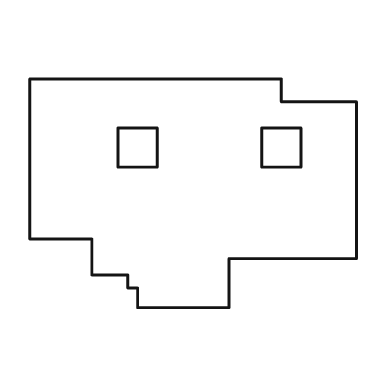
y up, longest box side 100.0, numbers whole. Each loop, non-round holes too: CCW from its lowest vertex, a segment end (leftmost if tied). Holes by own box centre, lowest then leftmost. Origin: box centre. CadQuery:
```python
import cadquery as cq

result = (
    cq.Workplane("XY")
    .moveTo(-17.0, -35.0)
    .lineTo(11.0, -35.0)
    .lineTo(11.0, -20.0)
    .lineTo(50.0, -20.0)
    .lineTo(50.0, 28.0)
    .lineTo(27.0, 28.0)
    .lineTo(27.0, 35.0)
    .lineTo(-50.0, 35.0)
    .lineTo(-50.0, -14.0)
    .lineTo(-31.0, -14.0)
    .lineTo(-31.0, -25.0)
    .lineTo(-20.0, -25.0)
    .lineTo(-20.0, -29.0)
    .lineTo(-17.0, -29.0)
    .close()
    .moveTo(-23.0, 8.0)
    .lineTo(-11.0, 8.0)
    .lineTo(-11.0, 20.0)
    .lineTo(-23.0, 20.0)
    .close()
    .moveTo(21.0, 8.0)
    .lineTo(33.0, 8.0)
    .lineTo(33.0, 20.0)
    .lineTo(21.0, 20.0)
    .close()
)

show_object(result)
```